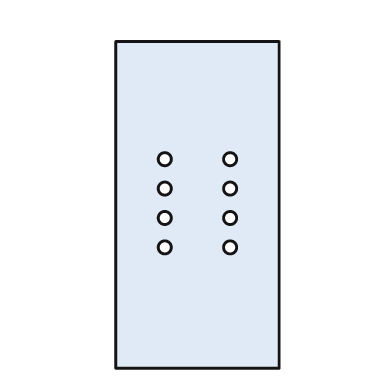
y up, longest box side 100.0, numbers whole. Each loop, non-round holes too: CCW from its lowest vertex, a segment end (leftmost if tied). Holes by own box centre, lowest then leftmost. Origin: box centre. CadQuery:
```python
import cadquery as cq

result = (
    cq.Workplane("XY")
    .moveTo(-25.0, -50.0)
    .lineTo(25.0, -50.0)
    .lineTo(25.0, 50.0)
    .lineTo(-25.0, 50.0)
    .close()
    .moveTo(-10.0, -13.0)
    .circle(2.0)
    .moveTo(10.0, -13.0)
    .circle(2.0)
    .moveTo(-10.0, -4.0)
    .circle(2.0)
    .moveTo(10.0, -4.0)
    .circle(2.0)
    .moveTo(-10.0, 5.0)
    .circle(2.0)
    .moveTo(10.0, 5.0)
    .circle(2.0)
    .moveTo(-10.0, 14.0)
    .circle(2.0)
    .moveTo(10.0, 14.0)
    .circle(2.0)
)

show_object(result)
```